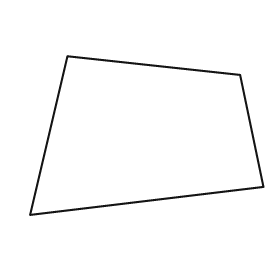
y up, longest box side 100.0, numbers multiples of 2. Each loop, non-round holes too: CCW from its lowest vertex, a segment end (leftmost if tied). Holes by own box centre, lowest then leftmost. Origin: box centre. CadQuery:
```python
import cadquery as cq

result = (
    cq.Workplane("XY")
    .moveTo(-50.0, -34.0)
    .lineTo(50.0, -22.0)
    .lineTo(40.0, 26.0)
    .lineTo(-34.0, 34.0)
    .close()
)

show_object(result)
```